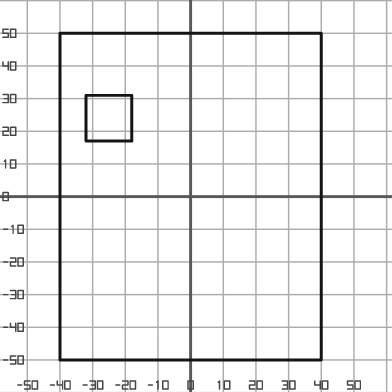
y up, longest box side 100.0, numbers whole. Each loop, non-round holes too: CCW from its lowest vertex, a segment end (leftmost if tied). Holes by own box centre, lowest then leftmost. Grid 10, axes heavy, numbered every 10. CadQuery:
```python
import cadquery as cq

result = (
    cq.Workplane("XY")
    .moveTo(-40.0, -50.0)
    .lineTo(40.0, -50.0)
    .lineTo(40.0, 50.0)
    .lineTo(-40.0, 50.0)
    .close()
    .moveTo(-32.0, 17.0)
    .lineTo(-18.0, 17.0)
    .lineTo(-18.0, 31.0)
    .lineTo(-32.0, 31.0)
    .close()
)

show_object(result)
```